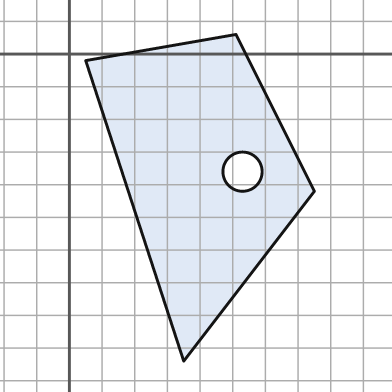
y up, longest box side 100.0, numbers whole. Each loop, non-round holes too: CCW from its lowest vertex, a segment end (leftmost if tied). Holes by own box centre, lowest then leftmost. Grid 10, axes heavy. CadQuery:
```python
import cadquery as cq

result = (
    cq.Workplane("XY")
    .moveTo(35.0, -94.0)
    .lineTo(75.0, -42.0)
    .lineTo(51.0, 6.0)
    .lineTo(5.0, -2.0)
    .close()
    .moveTo(53.0, -36.0)
    .circle(6.0)
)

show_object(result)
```